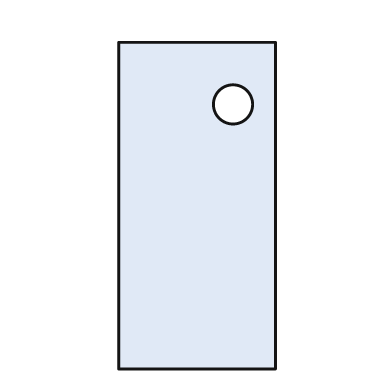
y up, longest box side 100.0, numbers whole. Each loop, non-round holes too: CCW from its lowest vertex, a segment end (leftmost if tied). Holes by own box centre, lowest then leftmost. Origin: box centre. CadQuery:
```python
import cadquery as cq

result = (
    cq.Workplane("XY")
    .moveTo(-24.0, -50.0)
    .lineTo(24.0, -50.0)
    .lineTo(24.0, 50.0)
    .lineTo(-24.0, 50.0)
    .close()
    .moveTo(11.0, 31.0)
    .circle(6.0)
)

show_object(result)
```